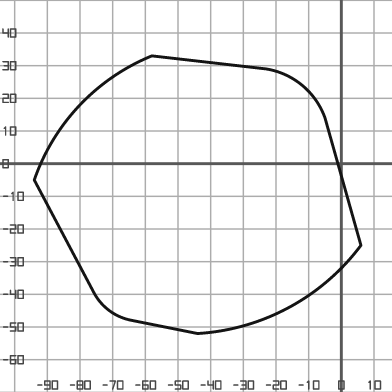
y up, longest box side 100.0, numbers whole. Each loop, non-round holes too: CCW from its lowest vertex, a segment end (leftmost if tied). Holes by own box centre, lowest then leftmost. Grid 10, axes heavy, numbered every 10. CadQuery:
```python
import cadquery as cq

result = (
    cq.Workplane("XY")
    .moveTo(-44.0, -52.0)
    .threePointArc((-16.0, -44.0), (6.0, -25.0))
    .lineTo(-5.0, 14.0)
    .threePointArc((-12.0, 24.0), (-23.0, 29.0))
    .lineTo(-58.0, 33.0)
    .threePointArc((-80.0, 18.0), (-94.0, -5.0))
    .lineTo(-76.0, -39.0)
    .threePointArc((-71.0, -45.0), (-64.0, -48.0))
    .close()
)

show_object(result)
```